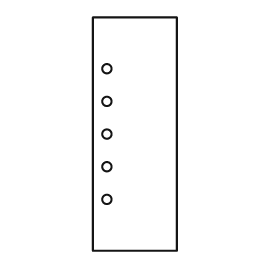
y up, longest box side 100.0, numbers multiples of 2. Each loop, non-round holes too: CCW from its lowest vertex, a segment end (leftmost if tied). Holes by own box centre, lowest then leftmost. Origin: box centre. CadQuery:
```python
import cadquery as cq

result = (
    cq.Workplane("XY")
    .moveTo(-18.0, -50.0)
    .lineTo(18.0, -50.0)
    .lineTo(18.0, 50.0)
    .lineTo(-18.0, 50.0)
    .close()
    .moveTo(-12.0, -28.0)
    .circle(2.0)
    .moveTo(-12.0, -14.0)
    .circle(2.0)
    .moveTo(-12.0, 0.0)
    .circle(2.0)
    .moveTo(-12.0, 14.0)
    .circle(2.0)
    .moveTo(-12.0, 28.0)
    .circle(2.0)
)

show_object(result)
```